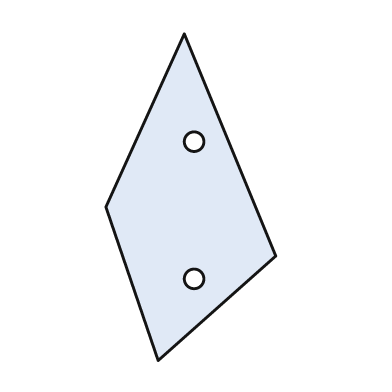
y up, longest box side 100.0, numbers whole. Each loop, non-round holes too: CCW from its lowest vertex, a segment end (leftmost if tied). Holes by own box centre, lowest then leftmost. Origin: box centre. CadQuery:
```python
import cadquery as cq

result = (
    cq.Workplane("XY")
    .moveTo(-10.0, -50.0)
    .lineTo(26.0, -18.0)
    .lineTo(-2.0, 50.0)
    .lineTo(-26.0, -3.0)
    .close()
    .moveTo(1.0, -25.0)
    .circle(3.0)
    .moveTo(1.0, 17.0)
    .circle(3.0)
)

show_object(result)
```